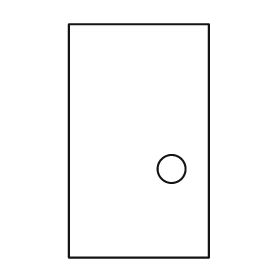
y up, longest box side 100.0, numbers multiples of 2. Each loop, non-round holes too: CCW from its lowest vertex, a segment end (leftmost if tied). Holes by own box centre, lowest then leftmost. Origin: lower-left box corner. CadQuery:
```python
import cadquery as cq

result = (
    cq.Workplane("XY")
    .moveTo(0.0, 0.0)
    .lineTo(60.0, 0.0)
    .lineTo(60.0, 100.0)
    .lineTo(0.0, 100.0)
    .close()
    .moveTo(44.0, 38.0)
    .circle(6.0)
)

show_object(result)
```